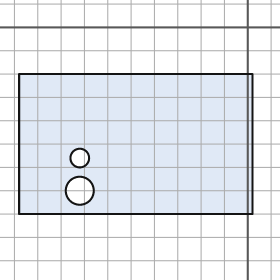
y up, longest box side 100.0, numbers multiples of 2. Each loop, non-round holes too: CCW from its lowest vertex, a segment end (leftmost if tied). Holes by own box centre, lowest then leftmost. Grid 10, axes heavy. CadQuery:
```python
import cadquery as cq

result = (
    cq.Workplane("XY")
    .moveTo(-98.0, -80.0)
    .lineTo(2.0, -80.0)
    .lineTo(2.0, -20.0)
    .lineTo(-98.0, -20.0)
    .close()
    .moveTo(-72.0, -70.0)
    .circle(6.0)
    .moveTo(-72.0, -56.0)
    .circle(4.0)
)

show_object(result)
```